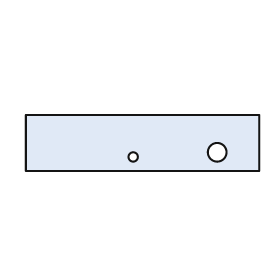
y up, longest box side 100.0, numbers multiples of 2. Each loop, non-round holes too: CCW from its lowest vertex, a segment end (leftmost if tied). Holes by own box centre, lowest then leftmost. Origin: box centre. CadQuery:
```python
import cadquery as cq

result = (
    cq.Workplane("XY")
    .moveTo(-50.0, -12.0)
    .lineTo(50.0, -12.0)
    .lineTo(50.0, 12.0)
    .lineTo(-50.0, 12.0)
    .close()
    .moveTo(-4.0, -6.0)
    .circle(2.0)
    .moveTo(32.0, -4.0)
    .circle(4.0)
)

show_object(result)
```